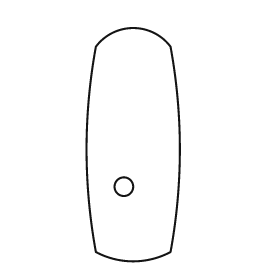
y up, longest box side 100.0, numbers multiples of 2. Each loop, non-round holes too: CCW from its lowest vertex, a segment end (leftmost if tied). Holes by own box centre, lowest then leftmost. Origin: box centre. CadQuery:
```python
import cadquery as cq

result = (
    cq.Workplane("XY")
    .moveTo(-16.0, -46.0)
    .threePointArc((0.0, -50.0), (16.0, -46.0))
    .threePointArc((20.0, -2.0), (16.0, 42.0))
    .threePointArc((0.0, 50.0), (-16.0, 42.0))
    .threePointArc((-20.0, -2.0), (-16.0, -46.0))
    .close()
    .moveTo(-4.0, -18.0)
    .circle(4.0)
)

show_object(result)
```